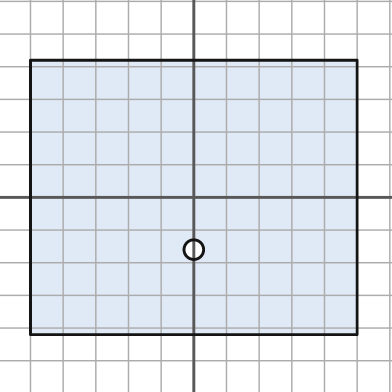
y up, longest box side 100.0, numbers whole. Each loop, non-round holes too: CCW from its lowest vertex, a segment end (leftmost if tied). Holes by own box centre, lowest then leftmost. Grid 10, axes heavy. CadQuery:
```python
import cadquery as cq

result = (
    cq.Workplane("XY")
    .moveTo(-50.0, -42.0)
    .lineTo(50.0, -42.0)
    .lineTo(50.0, 42.0)
    .lineTo(-50.0, 42.0)
    .close()
    .moveTo(0.0, -16.0)
    .circle(3.0)
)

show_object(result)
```